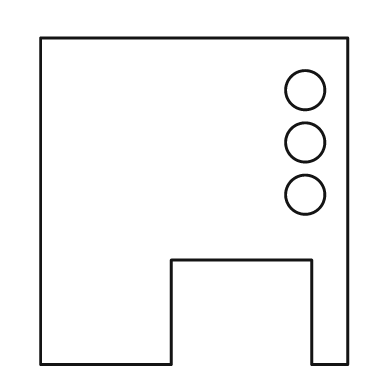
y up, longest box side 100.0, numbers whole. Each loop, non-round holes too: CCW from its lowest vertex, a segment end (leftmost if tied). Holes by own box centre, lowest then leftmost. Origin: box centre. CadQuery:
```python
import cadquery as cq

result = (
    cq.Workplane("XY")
    .moveTo(-47.0, -50.0)
    .lineTo(-7.0, -50.0)
    .lineTo(-7.0, -18.0)
    .lineTo(36.0, -18.0)
    .lineTo(36.0, -50.0)
    .lineTo(47.0, -50.0)
    .lineTo(47.0, 50.0)
    .lineTo(-47.0, 50.0)
    .close()
    .moveTo(34.0, 2.0)
    .circle(6.0)
    .moveTo(34.0, 18.0)
    .circle(6.0)
    .moveTo(34.0, 34.0)
    .circle(6.0)
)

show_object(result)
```